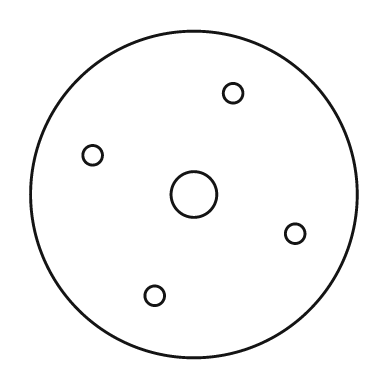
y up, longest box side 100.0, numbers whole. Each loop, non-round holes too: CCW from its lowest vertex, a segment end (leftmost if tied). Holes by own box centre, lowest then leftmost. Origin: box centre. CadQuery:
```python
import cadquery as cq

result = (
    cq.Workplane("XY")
    .moveTo(0.0, 0.0)
    .circle(50.0)
    .moveTo(-12.0, -31.0)
    .circle(3.0)
    .moveTo(31.0, -12.0)
    .circle(3.0)
    .moveTo(0.0, 0.0)
    .circle(7.0)
    .moveTo(-31.0, 12.0)
    .circle(3.0)
    .moveTo(12.0, 31.0)
    .circle(3.0)
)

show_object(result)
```